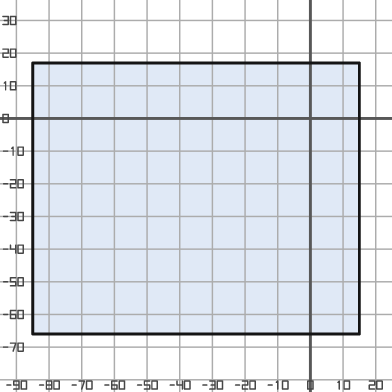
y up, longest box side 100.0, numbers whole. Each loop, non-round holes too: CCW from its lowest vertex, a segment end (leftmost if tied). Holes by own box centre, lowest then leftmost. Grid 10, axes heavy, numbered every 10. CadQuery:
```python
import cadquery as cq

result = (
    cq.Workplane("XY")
    .moveTo(-85.0, -66.0)
    .lineTo(15.0, -66.0)
    .lineTo(15.0, 17.0)
    .lineTo(-85.0, 17.0)
    .close()
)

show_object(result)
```